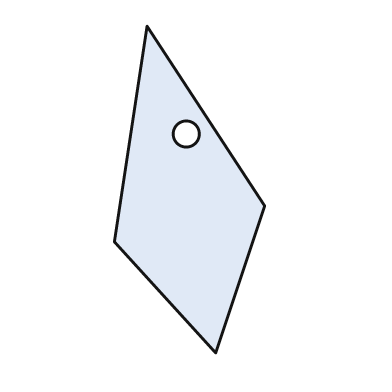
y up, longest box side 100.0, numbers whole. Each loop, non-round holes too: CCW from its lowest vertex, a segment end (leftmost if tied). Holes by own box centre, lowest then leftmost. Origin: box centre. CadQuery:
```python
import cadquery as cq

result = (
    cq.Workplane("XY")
    .moveTo(8.0, -50.0)
    .lineTo(23.0, -5.0)
    .lineTo(-13.0, 50.0)
    .lineTo(-23.0, -16.0)
    .close()
    .moveTo(-1.0, 17.0)
    .circle(4.0)
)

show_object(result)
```